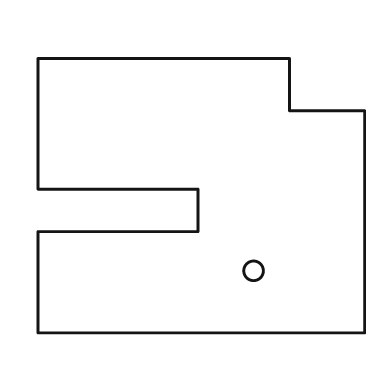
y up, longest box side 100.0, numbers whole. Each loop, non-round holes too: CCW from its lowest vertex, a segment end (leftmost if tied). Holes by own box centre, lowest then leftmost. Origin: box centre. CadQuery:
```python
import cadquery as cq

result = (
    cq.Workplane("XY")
    .moveTo(-50.0, -42.0)
    .lineTo(50.0, -42.0)
    .lineTo(50.0, 26.0)
    .lineTo(27.0, 26.0)
    .lineTo(27.0, 42.0)
    .lineTo(-50.0, 42.0)
    .lineTo(-50.0, 2.0)
    .lineTo(-1.0, 2.0)
    .lineTo(-1.0, -11.0)
    .lineTo(-50.0, -11.0)
    .close()
    .moveTo(16.0, -23.0)
    .circle(3.0)
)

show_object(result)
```